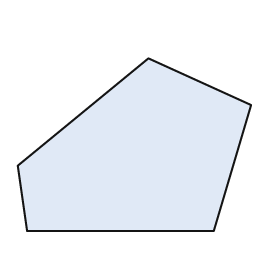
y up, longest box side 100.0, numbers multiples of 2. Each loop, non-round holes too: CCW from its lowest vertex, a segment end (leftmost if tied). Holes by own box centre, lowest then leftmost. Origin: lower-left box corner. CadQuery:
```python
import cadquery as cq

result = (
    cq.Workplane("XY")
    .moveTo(4.0, 0.0)
    .lineTo(84.0, 0.0)
    .lineTo(100.0, 54.0)
    .lineTo(56.0, 74.0)
    .lineTo(0.0, 28.0)
    .close()
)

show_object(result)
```